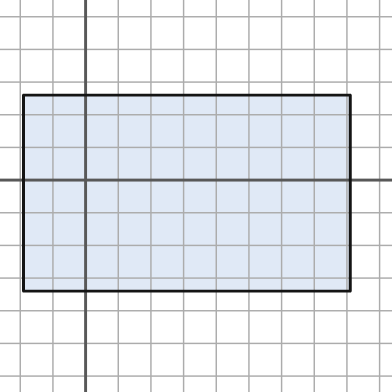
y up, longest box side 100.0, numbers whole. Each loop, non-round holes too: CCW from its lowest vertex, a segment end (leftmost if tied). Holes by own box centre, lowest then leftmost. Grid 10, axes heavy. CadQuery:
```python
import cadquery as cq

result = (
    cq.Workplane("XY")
    .moveTo(-19.0, -34.0)
    .lineTo(81.0, -34.0)
    .lineTo(81.0, 26.0)
    .lineTo(-19.0, 26.0)
    .close()
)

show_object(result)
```